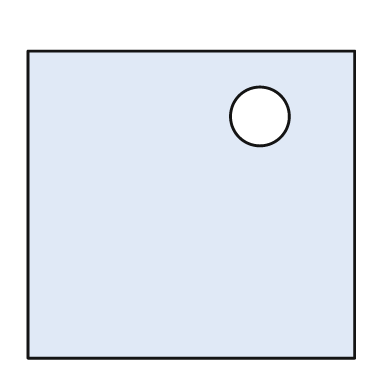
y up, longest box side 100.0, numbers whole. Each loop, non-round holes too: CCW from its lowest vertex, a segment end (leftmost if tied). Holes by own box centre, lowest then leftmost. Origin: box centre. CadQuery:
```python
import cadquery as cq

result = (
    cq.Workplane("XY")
    .moveTo(-50.0, -47.0)
    .lineTo(50.0, -47.0)
    .lineTo(50.0, 47.0)
    .lineTo(-50.0, 47.0)
    .close()
    .moveTo(21.0, 27.0)
    .circle(9.0)
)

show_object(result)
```